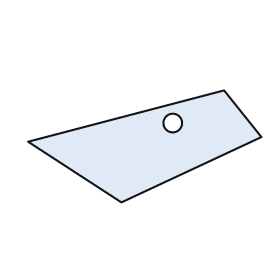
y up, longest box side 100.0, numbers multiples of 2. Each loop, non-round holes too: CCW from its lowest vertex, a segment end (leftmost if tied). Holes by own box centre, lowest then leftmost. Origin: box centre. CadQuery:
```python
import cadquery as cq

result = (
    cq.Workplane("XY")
    .moveTo(-10.0, -24.0)
    .lineTo(50.0, 4.0)
    .lineTo(34.0, 24.0)
    .lineTo(-50.0, 2.0)
    .close()
    .moveTo(12.0, 10.0)
    .circle(4.0)
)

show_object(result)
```